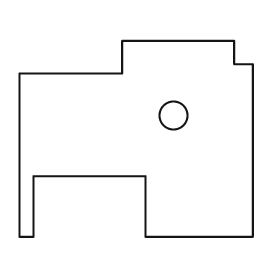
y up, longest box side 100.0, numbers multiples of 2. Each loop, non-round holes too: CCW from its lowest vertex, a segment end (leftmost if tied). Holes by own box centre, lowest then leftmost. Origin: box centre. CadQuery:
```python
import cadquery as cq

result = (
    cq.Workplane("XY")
    .moveTo(-50.0, -42.0)
    .lineTo(-44.0, -42.0)
    .lineTo(-44.0, -16.0)
    .lineTo(4.0, -16.0)
    .lineTo(4.0, -42.0)
    .lineTo(50.0, -42.0)
    .lineTo(50.0, 32.0)
    .lineTo(42.0, 32.0)
    .lineTo(42.0, 42.0)
    .lineTo(-6.0, 42.0)
    .lineTo(-6.0, 28.0)
    .lineTo(-50.0, 28.0)
    .close()
    .moveTo(16.0, 10.0)
    .circle(6.0)
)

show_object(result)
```